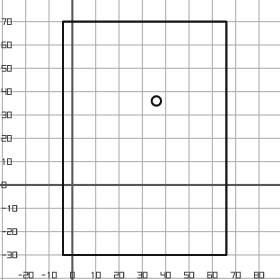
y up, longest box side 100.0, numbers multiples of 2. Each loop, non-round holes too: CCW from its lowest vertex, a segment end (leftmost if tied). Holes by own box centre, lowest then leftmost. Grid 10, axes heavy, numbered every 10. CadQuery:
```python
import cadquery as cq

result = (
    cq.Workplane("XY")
    .moveTo(-4.0, -30.0)
    .lineTo(66.0, -30.0)
    .lineTo(66.0, 70.0)
    .lineTo(-4.0, 70.0)
    .close()
    .moveTo(36.0, 36.0)
    .circle(2.0)
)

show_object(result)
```